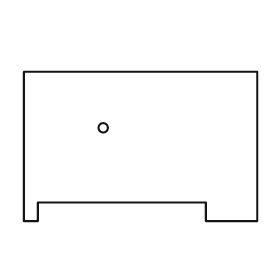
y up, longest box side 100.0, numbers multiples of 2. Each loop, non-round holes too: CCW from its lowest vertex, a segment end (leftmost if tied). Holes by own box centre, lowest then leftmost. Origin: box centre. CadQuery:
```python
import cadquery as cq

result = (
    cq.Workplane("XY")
    .moveTo(-50.0, -32.0)
    .lineTo(-44.0, -32.0)
    .lineTo(-44.0, -24.0)
    .lineTo(28.0, -24.0)
    .lineTo(28.0, -32.0)
    .lineTo(50.0, -32.0)
    .lineTo(50.0, 32.0)
    .lineTo(-50.0, 32.0)
    .close()
    .moveTo(-16.0, 8.0)
    .circle(2.0)
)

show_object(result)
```